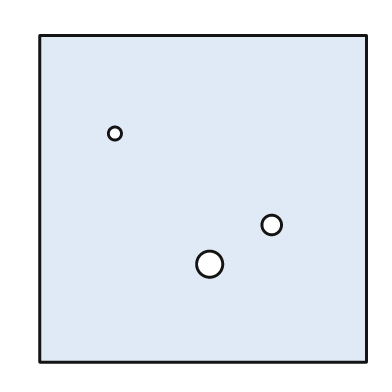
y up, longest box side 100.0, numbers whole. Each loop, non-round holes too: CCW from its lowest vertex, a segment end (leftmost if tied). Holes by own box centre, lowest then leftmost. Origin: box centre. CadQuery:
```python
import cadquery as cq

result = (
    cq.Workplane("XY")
    .moveTo(-50.0, -50.0)
    .lineTo(50.0, -50.0)
    .lineTo(50.0, 50.0)
    .lineTo(-50.0, 50.0)
    .close()
    .moveTo(2.0, -20.0)
    .circle(4.0)
    .moveTo(21.0, -8.0)
    .circle(3.0)
    .moveTo(-27.0, 20.0)
    .circle(2.0)
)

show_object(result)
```